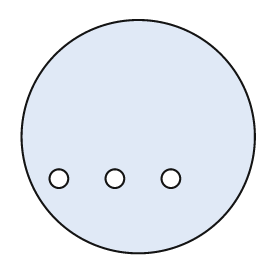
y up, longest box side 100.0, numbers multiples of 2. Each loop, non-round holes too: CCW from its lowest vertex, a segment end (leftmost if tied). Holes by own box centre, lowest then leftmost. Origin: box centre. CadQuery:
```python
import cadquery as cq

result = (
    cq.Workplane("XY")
    .moveTo(0.0, 0.0)
    .circle(50.0)
    .moveTo(-34.0, -18.0)
    .circle(4.0)
    .moveTo(-10.0, -18.0)
    .circle(4.0)
    .moveTo(14.0, -18.0)
    .circle(4.0)
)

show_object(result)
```